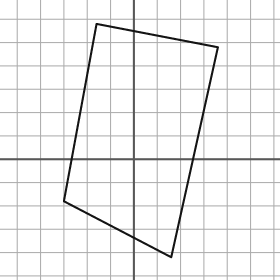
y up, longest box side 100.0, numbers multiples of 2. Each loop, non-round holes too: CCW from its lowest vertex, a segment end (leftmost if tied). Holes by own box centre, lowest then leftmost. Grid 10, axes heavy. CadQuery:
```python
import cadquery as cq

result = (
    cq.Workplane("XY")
    .moveTo(16.0, -42.0)
    .lineTo(36.0, 48.0)
    .lineTo(-16.0, 58.0)
    .lineTo(-30.0, -18.0)
    .close()
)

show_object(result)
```